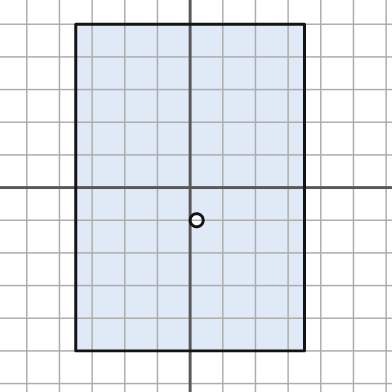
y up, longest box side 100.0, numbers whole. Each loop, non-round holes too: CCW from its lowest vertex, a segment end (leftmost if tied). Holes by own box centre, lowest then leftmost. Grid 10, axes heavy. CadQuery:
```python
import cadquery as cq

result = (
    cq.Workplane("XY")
    .moveTo(-35.0, -50.0)
    .lineTo(35.0, -50.0)
    .lineTo(35.0, 50.0)
    .lineTo(-35.0, 50.0)
    .close()
    .moveTo(2.0, -10.0)
    .circle(2.0)
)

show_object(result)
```